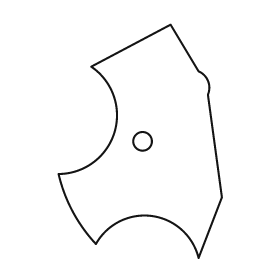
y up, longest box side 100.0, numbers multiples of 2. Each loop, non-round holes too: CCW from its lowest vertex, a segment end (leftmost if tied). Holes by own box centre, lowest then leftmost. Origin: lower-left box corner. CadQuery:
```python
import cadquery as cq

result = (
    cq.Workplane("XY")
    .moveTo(60.0, 0.0)
    .lineTo(70.0, 26.0)
    .lineTo(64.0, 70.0)
    .threePointArc((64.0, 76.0), (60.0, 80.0))
    .lineTo(48.0, 100.0)
    .lineTo(14.0, 82.0)
    .threePointArc((24.0, 54.0), (0.0, 36.0))
    .threePointArc((6.0, 20.0), (16.0, 6.0))
    .threePointArc((40.0, 18.0), (60.0, 0.0))
    .close()
    .moveTo(36.0, 50.0)
    .circle(4.0)
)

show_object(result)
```